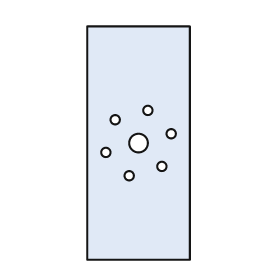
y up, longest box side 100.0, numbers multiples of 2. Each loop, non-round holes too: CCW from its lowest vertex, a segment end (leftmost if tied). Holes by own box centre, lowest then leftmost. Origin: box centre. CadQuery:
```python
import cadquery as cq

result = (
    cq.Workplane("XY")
    .moveTo(-22.0, -50.0)
    .lineTo(22.0, -50.0)
    .lineTo(22.0, 50.0)
    .lineTo(-22.0, 50.0)
    .close()
    .moveTo(-4.0, -14.0)
    .circle(2.0)
    .moveTo(10.0, -10.0)
    .circle(2.0)
    .moveTo(-14.0, -4.0)
    .circle(2.0)
    .moveTo(0.0, 0.0)
    .circle(4.0)
    .moveTo(14.0, 4.0)
    .circle(2.0)
    .moveTo(-10.0, 10.0)
    .circle(2.0)
    .moveTo(4.0, 14.0)
    .circle(2.0)
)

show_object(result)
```